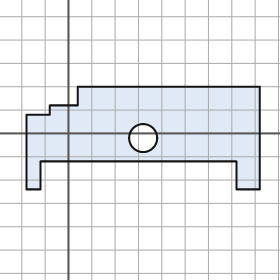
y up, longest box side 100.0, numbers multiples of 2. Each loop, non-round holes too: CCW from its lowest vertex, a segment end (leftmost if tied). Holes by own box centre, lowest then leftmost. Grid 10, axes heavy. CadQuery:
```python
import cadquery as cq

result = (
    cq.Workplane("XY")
    .moveTo(-18.0, -24.0)
    .lineTo(-12.0, -24.0)
    .lineTo(-12.0, -12.0)
    .lineTo(72.0, -12.0)
    .lineTo(72.0, -24.0)
    .lineTo(82.0, -24.0)
    .lineTo(82.0, 20.0)
    .lineTo(4.0, 20.0)
    .lineTo(4.0, 12.0)
    .lineTo(-8.0, 12.0)
    .lineTo(-8.0, 8.0)
    .lineTo(-18.0, 8.0)
    .close()
    .moveTo(32.0, -2.0)
    .circle(6.0)
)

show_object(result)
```